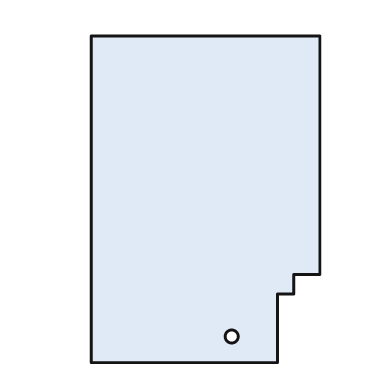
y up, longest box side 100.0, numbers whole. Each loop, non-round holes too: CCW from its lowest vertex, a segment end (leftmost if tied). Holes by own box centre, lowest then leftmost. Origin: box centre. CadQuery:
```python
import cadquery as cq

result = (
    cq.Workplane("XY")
    .moveTo(-35.0, -50.0)
    .lineTo(22.0, -50.0)
    .lineTo(22.0, -29.0)
    .lineTo(27.0, -29.0)
    .lineTo(27.0, -23.0)
    .lineTo(35.0, -23.0)
    .lineTo(35.0, 50.0)
    .lineTo(-35.0, 50.0)
    .close()
    .moveTo(8.0, -42.0)
    .circle(2.0)
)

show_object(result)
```